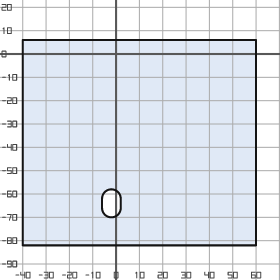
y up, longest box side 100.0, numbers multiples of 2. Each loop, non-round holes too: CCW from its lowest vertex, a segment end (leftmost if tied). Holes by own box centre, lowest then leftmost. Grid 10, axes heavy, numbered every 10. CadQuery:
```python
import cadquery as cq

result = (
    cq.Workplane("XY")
    .moveTo(-40.0, -82.0)
    .lineTo(60.0, -82.0)
    .lineTo(60.0, 6.0)
    .lineTo(-40.0, 6.0)
    .close()
    .moveTo(-6.0, -66.0)
    .threePointArc((-2.0, -70.0), (2.0, -66.0))
    .lineTo(2.0, -62.0)
    .threePointArc((-2.0, -58.0), (-6.0, -62.0))
    .close()
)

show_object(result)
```